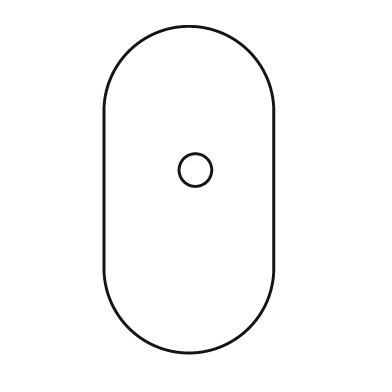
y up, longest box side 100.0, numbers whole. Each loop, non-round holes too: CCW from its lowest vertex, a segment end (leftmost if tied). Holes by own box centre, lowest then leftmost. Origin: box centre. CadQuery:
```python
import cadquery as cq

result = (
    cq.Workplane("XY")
    .moveTo(-26.0, -24.0)
    .threePointArc((0.0, -50.0), (26.0, -24.0))
    .lineTo(26.0, 24.0)
    .threePointArc((0.0, 50.0), (-26.0, 24.0))
    .close()
    .moveTo(2.0, 6.0)
    .circle(5.0)
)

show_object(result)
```